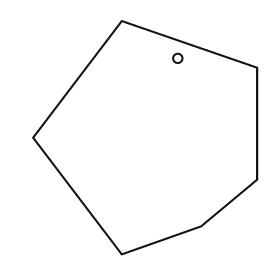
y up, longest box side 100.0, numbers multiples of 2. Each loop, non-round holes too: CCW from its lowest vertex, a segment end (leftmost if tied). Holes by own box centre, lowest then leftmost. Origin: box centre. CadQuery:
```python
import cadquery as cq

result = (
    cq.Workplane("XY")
    .moveTo(-10.0, -50.0)
    .lineTo(24.0, -38.0)
    .lineTo(48.0, -18.0)
    .lineTo(48.0, 30.0)
    .lineTo(-10.0, 50.0)
    .lineTo(-48.0, 0.0)
    .close()
    .moveTo(14.0, 34.0)
    .circle(2.0)
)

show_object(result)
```